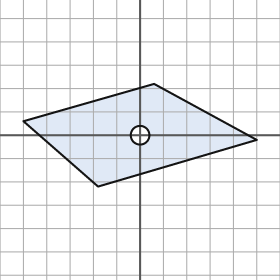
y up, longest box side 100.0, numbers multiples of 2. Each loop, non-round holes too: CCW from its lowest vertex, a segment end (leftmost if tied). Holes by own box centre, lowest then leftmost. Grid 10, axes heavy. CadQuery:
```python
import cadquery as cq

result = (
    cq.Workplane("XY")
    .moveTo(-18.0, -22.0)
    .lineTo(50.0, -2.0)
    .lineTo(6.0, 22.0)
    .lineTo(-50.0, 6.0)
    .close()
    .moveTo(0.0, 0.0)
    .circle(4.0)
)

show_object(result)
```